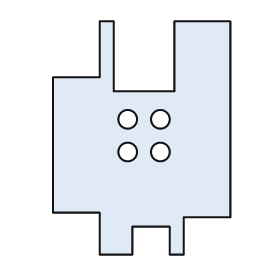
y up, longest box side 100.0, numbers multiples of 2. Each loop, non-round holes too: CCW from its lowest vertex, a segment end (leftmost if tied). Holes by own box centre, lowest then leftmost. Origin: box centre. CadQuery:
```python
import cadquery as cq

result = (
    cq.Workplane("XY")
    .moveTo(-18.0, -50.0)
    .lineTo(-4.0, -50.0)
    .lineTo(-4.0, -38.0)
    .lineTo(12.0, -38.0)
    .lineTo(12.0, -50.0)
    .lineTo(18.0, -50.0)
    .lineTo(18.0, -34.0)
    .lineTo(38.0, -34.0)
    .lineTo(38.0, 50.0)
    .lineTo(14.0, 50.0)
    .lineTo(14.0, 20.0)
    .lineTo(-12.0, 20.0)
    .lineTo(-12.0, 50.0)
    .lineTo(-18.0, 50.0)
    .lineTo(-18.0, 26.0)
    .lineTo(-38.0, 26.0)
    .lineTo(-38.0, -32.0)
    .lineTo(-18.0, -32.0)
    .close()
    .moveTo(-6.0, -6.0)
    .circle(4.0)
    .moveTo(8.0, -6.0)
    .circle(4.0)
    .moveTo(-6.0, 8.0)
    .circle(4.0)
    .moveTo(8.0, 8.0)
    .circle(4.0)
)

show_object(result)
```